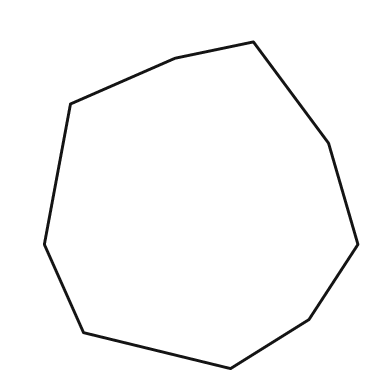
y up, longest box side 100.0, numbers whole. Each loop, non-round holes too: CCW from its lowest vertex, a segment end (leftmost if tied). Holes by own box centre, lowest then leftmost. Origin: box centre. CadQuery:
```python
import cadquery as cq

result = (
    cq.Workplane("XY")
    .moveTo(9.0, -50.0)
    .lineTo(33.0, -35.0)
    .lineTo(48.0, -12.0)
    .lineTo(39.0, 19.0)
    .lineTo(16.0, 50.0)
    .lineTo(-8.0, 45.0)
    .lineTo(-40.0, 31.0)
    .lineTo(-48.0, -12.0)
    .lineTo(-36.0, -39.0)
    .close()
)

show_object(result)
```